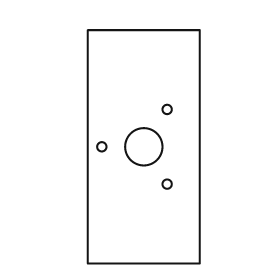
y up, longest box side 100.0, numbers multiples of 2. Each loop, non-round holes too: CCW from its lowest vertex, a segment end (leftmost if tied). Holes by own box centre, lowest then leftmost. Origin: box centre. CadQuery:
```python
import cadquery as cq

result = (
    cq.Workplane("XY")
    .moveTo(-24.0, -50.0)
    .lineTo(24.0, -50.0)
    .lineTo(24.0, 50.0)
    .lineTo(-24.0, 50.0)
    .close()
    .moveTo(10.0, -16.0)
    .circle(2.0)
    .moveTo(-18.0, 0.0)
    .circle(2.0)
    .moveTo(0.0, 0.0)
    .circle(8.0)
    .moveTo(10.0, 16.0)
    .circle(2.0)
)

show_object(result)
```